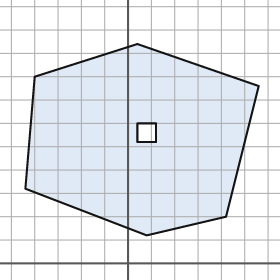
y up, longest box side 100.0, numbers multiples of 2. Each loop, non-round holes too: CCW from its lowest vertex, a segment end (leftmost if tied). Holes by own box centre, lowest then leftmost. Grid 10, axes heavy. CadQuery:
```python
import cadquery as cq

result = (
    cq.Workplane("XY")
    .moveTo(8.0, 12.0)
    .lineTo(42.0, 20.0)
    .lineTo(56.0, 76.0)
    .lineTo(4.0, 94.0)
    .lineTo(-40.0, 80.0)
    .lineTo(-44.0, 32.0)
    .close()
    .moveTo(4.0, 52.0)
    .lineTo(12.0, 52.0)
    .lineTo(12.0, 60.0)
    .lineTo(4.0, 60.0)
    .close()
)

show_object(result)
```